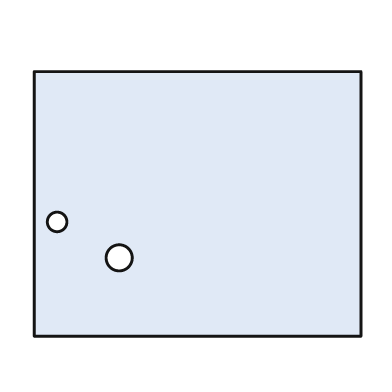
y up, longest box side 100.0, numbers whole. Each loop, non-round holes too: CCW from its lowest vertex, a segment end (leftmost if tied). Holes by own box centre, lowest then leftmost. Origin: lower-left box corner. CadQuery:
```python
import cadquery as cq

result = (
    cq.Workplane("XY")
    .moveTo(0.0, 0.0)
    .lineTo(100.0, 0.0)
    .lineTo(100.0, 81.0)
    .lineTo(0.0, 81.0)
    .close()
    .moveTo(26.0, 24.0)
    .circle(4.0)
    .moveTo(7.0, 35.0)
    .circle(3.0)
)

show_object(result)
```